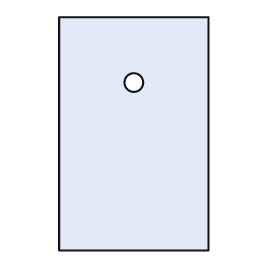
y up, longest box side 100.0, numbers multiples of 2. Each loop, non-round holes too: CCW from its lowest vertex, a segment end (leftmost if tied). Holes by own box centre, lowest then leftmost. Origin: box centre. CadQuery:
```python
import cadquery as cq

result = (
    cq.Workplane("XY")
    .moveTo(-32.0, -50.0)
    .lineTo(32.0, -50.0)
    .lineTo(32.0, 50.0)
    .lineTo(-32.0, 50.0)
    .close()
    .moveTo(0.0, 22.0)
    .circle(4.0)
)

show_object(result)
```